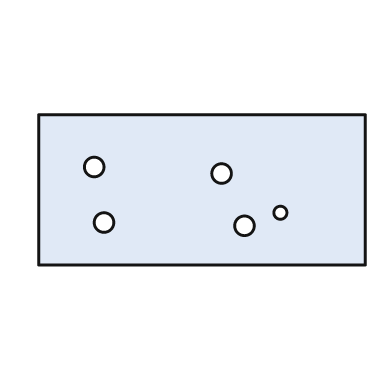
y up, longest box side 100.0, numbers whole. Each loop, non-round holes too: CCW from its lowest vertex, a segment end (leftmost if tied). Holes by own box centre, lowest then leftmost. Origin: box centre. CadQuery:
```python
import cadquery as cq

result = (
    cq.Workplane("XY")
    .moveTo(-50.0, -23.0)
    .lineTo(50.0, -23.0)
    .lineTo(50.0, 23.0)
    .lineTo(-50.0, 23.0)
    .close()
    .moveTo(13.0, -11.0)
    .circle(3.0)
    .moveTo(-30.0, -10.0)
    .circle(3.0)
    .moveTo(24.0, -7.0)
    .circle(2.0)
    .moveTo(6.0, 5.0)
    .circle(3.0)
    .moveTo(-33.0, 7.0)
    .circle(3.0)
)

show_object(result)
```